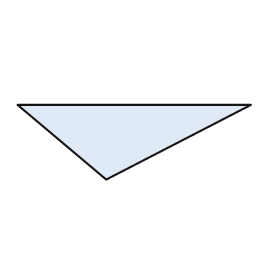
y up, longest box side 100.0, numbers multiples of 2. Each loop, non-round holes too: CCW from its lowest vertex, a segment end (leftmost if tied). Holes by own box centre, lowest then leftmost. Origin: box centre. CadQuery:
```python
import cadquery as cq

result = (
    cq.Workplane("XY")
    .moveTo(-12.0, -16.0)
    .lineTo(50.0, 16.0)
    .lineTo(-50.0, 16.0)
    .close()
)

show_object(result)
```